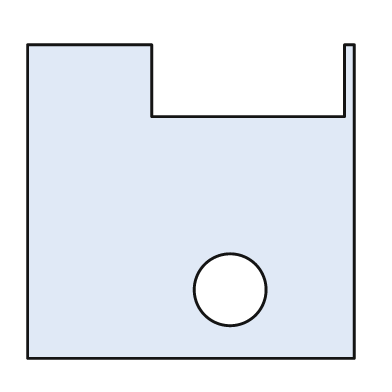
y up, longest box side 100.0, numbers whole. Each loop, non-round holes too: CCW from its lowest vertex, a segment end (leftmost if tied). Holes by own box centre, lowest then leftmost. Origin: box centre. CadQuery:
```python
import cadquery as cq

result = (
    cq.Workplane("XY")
    .moveTo(-50.0, -48.0)
    .lineTo(50.0, -48.0)
    .lineTo(50.0, 48.0)
    .lineTo(47.0, 48.0)
    .lineTo(47.0, 26.0)
    .lineTo(-12.0, 26.0)
    .lineTo(-12.0, 48.0)
    .lineTo(-50.0, 48.0)
    .close()
    .moveTo(12.0, -27.0)
    .circle(11.0)
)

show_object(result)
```